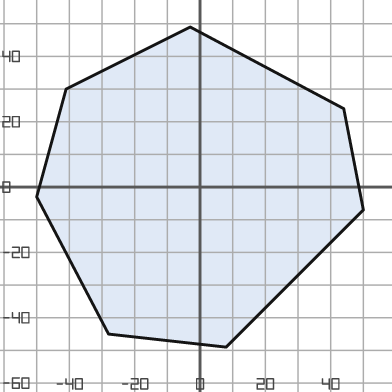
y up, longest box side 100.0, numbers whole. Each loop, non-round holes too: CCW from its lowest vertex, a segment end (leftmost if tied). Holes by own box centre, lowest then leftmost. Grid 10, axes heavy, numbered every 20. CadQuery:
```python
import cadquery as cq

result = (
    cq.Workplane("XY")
    .moveTo(8.0, -49.0)
    .lineTo(50.0, -7.0)
    .lineTo(44.0, 24.0)
    .lineTo(-3.0, 49.0)
    .lineTo(-41.0, 30.0)
    .lineTo(-50.0, -3.0)
    .lineTo(-28.0, -45.0)
    .close()
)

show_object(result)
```